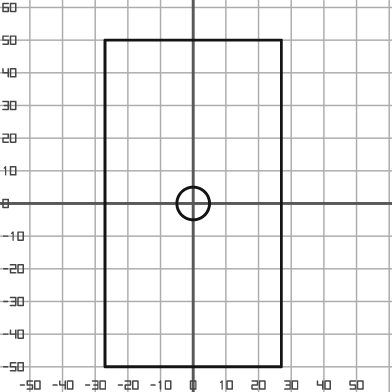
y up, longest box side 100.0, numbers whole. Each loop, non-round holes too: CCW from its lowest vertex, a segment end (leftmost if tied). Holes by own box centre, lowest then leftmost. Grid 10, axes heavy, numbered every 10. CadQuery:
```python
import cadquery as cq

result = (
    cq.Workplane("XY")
    .moveTo(-27.0, -50.0)
    .lineTo(27.0, -50.0)
    .lineTo(27.0, 50.0)
    .lineTo(-27.0, 50.0)
    .close()
    .moveTo(0.0, 0.0)
    .circle(5.0)
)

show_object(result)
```